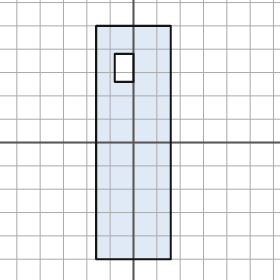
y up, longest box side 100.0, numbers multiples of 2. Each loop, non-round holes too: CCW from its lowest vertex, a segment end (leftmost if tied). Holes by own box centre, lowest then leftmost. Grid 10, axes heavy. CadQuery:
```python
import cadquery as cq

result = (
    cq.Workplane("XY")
    .moveTo(-16.0, -50.0)
    .lineTo(16.0, -50.0)
    .lineTo(16.0, 50.0)
    .lineTo(-16.0, 50.0)
    .close()
    .moveTo(-8.0, 26.0)
    .lineTo(0.0, 26.0)
    .lineTo(0.0, 38.0)
    .lineTo(-8.0, 38.0)
    .close()
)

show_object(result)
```